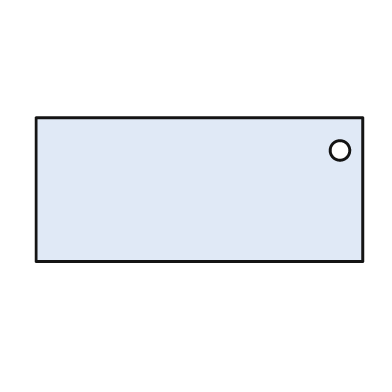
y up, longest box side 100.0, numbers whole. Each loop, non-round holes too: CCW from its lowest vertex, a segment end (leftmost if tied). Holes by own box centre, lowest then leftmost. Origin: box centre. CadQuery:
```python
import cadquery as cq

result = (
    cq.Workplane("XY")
    .moveTo(-50.0, -22.0)
    .lineTo(50.0, -22.0)
    .lineTo(50.0, 22.0)
    .lineTo(-50.0, 22.0)
    .close()
    .moveTo(43.0, 12.0)
    .circle(3.0)
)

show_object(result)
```